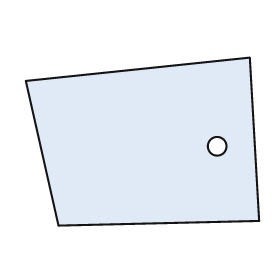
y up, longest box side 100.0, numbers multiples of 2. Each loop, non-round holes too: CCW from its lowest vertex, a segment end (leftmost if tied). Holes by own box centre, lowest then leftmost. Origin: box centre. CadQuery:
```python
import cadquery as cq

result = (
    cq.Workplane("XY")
    .moveTo(-36.0, -36.0)
    .lineTo(50.0, -34.0)
    .lineTo(46.0, 36.0)
    .lineTo(-50.0, 26.0)
    .close()
    .moveTo(32.0, -2.0)
    .circle(4.0)
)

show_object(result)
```